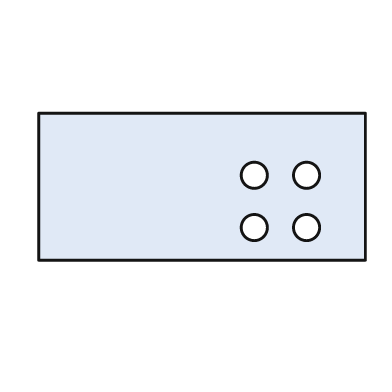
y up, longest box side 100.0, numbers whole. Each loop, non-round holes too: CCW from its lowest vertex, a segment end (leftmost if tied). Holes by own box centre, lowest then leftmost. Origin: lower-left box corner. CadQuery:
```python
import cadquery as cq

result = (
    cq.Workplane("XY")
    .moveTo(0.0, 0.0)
    .lineTo(100.0, 0.0)
    .lineTo(100.0, 45.0)
    .lineTo(0.0, 45.0)
    .close()
    .moveTo(66.0, 10.0)
    .circle(4.0)
    .moveTo(82.0, 10.0)
    .circle(4.0)
    .moveTo(66.0, 26.0)
    .circle(4.0)
    .moveTo(82.0, 26.0)
    .circle(4.0)
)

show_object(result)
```